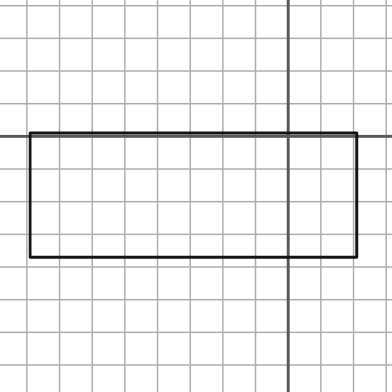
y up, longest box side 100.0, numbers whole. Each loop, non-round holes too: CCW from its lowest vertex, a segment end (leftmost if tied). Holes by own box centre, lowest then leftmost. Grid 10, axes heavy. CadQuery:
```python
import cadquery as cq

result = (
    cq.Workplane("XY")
    .moveTo(-79.0, -37.0)
    .lineTo(21.0, -37.0)
    .lineTo(21.0, 1.0)
    .lineTo(-79.0, 1.0)
    .close()
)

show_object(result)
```